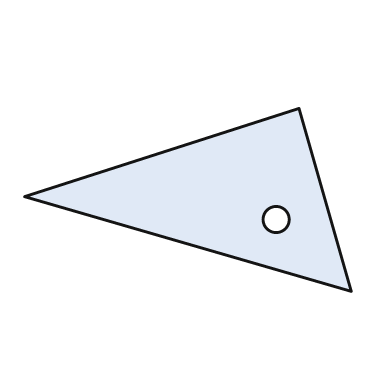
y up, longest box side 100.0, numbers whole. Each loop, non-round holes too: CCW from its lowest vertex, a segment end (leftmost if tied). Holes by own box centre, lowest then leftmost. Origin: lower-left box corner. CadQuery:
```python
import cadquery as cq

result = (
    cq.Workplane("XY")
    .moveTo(100.0, 0.0)
    .lineTo(84.0, 56.0)
    .lineTo(0.0, 29.0)
    .close()
    .moveTo(77.0, 22.0)
    .circle(4.0)
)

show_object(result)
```